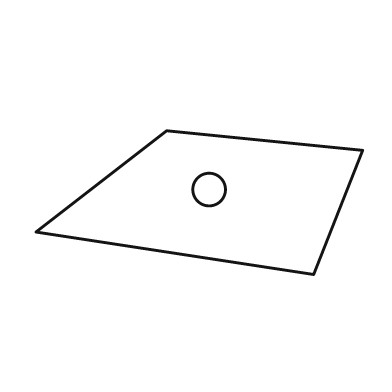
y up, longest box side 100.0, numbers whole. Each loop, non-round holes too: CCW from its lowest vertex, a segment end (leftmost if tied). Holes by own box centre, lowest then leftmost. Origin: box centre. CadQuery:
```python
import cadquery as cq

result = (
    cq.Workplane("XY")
    .moveTo(35.0, -22.0)
    .lineTo(50.0, 16.0)
    .lineTo(-10.0, 22.0)
    .lineTo(-50.0, -9.0)
    .close()
    .moveTo(3.0, 4.0)
    .circle(5.0)
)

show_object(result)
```